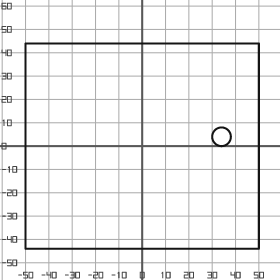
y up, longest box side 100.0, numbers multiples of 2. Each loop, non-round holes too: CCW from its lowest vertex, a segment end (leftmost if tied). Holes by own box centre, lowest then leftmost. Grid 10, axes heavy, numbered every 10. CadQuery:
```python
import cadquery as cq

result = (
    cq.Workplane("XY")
    .moveTo(-50.0, -44.0)
    .lineTo(50.0, -44.0)
    .lineTo(50.0, 44.0)
    .lineTo(-50.0, 44.0)
    .close()
    .moveTo(34.0, 4.0)
    .circle(4.0)
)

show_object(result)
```